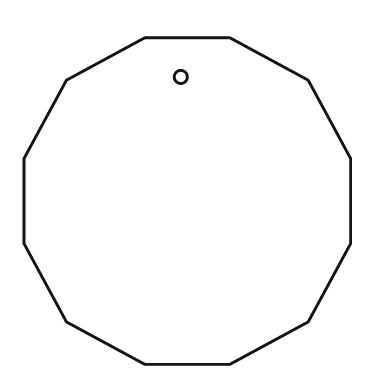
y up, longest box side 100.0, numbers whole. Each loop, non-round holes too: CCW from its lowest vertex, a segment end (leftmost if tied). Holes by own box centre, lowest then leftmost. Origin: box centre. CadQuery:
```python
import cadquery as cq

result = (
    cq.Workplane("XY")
    .moveTo(-13.0, -50.0)
    .lineTo(13.0, -50.0)
    .lineTo(37.0, -37.0)
    .lineTo(50.0, -13.0)
    .lineTo(50.0, 13.0)
    .lineTo(37.0, 37.0)
    .lineTo(13.0, 50.0)
    .lineTo(-13.0, 50.0)
    .lineTo(-37.0, 37.0)
    .lineTo(-50.0, 13.0)
    .lineTo(-50.0, -13.0)
    .lineTo(-37.0, -37.0)
    .close()
    .moveTo(-2.0, 38.0)
    .circle(2.0)
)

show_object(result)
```